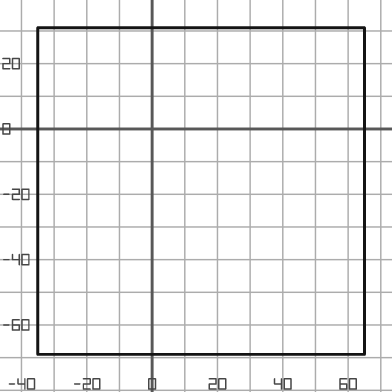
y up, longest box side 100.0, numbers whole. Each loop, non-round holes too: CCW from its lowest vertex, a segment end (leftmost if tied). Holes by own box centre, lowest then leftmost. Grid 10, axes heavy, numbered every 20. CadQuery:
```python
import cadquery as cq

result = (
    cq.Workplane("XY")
    .moveTo(-35.0, -69.0)
    .lineTo(65.0, -69.0)
    .lineTo(65.0, 31.0)
    .lineTo(-35.0, 31.0)
    .close()
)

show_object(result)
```